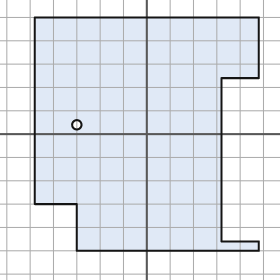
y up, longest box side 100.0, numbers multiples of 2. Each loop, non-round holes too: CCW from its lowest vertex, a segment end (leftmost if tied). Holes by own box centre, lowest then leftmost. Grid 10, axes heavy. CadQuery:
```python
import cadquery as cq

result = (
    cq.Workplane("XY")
    .moveTo(-30.0, -50.0)
    .lineTo(48.0, -50.0)
    .lineTo(48.0, -46.0)
    .lineTo(32.0, -46.0)
    .lineTo(32.0, 24.0)
    .lineTo(48.0, 24.0)
    .lineTo(48.0, 50.0)
    .lineTo(-48.0, 50.0)
    .lineTo(-48.0, -30.0)
    .lineTo(-30.0, -30.0)
    .close()
    .moveTo(-30.0, 4.0)
    .circle(2.0)
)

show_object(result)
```